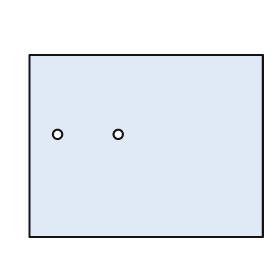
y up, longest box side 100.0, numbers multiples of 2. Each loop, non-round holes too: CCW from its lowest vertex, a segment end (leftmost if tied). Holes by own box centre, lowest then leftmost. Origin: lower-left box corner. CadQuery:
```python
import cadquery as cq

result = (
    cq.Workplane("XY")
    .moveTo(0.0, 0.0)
    .lineTo(100.0, 0.0)
    .lineTo(100.0, 78.0)
    .lineTo(0.0, 78.0)
    .close()
    .moveTo(12.0, 44.0)
    .circle(2.0)
    .moveTo(38.0, 44.0)
    .circle(2.0)
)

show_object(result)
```